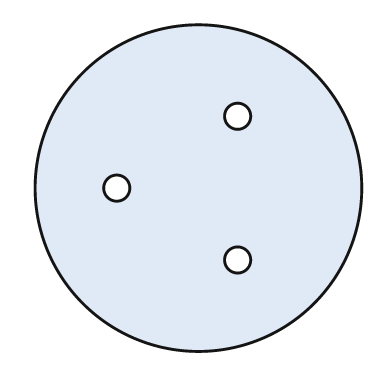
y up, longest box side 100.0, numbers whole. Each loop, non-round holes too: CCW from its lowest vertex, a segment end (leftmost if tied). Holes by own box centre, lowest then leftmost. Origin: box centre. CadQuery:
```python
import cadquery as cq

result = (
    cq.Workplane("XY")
    .moveTo(0.0, 0.0)
    .circle(50.0)
    .moveTo(12.0, -22.0)
    .circle(4.0)
    .moveTo(-25.0, 0.0)
    .circle(4.0)
    .moveTo(12.0, 22.0)
    .circle(4.0)
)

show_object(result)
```